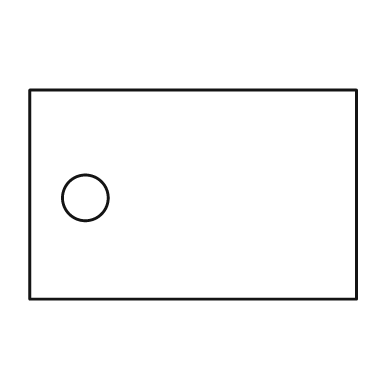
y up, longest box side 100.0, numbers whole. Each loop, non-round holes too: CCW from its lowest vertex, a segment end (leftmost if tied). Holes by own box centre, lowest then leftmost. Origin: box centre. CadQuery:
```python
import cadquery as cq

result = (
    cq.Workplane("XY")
    .moveTo(-50.0, -32.0)
    .lineTo(50.0, -32.0)
    .lineTo(50.0, 32.0)
    .lineTo(-50.0, 32.0)
    .close()
    .moveTo(-33.0, -1.0)
    .circle(7.0)
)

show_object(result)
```